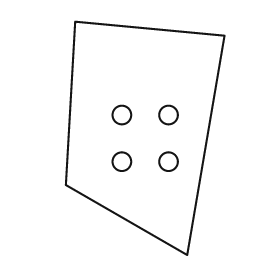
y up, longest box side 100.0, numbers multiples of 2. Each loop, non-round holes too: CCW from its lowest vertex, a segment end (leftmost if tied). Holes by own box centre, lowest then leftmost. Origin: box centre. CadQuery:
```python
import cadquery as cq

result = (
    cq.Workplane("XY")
    .moveTo(18.0, -50.0)
    .lineTo(34.0, 44.0)
    .lineTo(-30.0, 50.0)
    .lineTo(-34.0, -20.0)
    .close()
    .moveTo(-10.0, -10.0)
    .circle(4.0)
    .moveTo(10.0, -10.0)
    .circle(4.0)
    .moveTo(-10.0, 10.0)
    .circle(4.0)
    .moveTo(10.0, 10.0)
    .circle(4.0)
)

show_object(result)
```